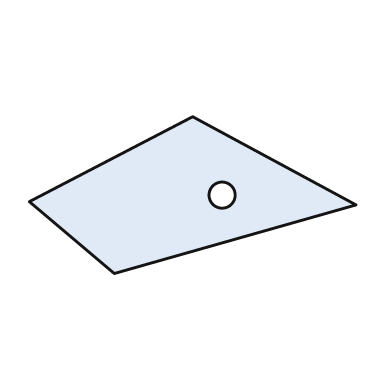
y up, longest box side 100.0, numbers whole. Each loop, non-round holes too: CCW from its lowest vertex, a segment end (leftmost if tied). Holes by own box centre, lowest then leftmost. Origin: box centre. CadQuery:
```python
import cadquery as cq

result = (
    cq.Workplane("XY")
    .moveTo(-24.0, -24.0)
    .lineTo(50.0, -3.0)
    .lineTo(0.0, 24.0)
    .lineTo(-50.0, -2.0)
    .close()
    .moveTo(9.0, 0.0)
    .circle(4.0)
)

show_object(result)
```